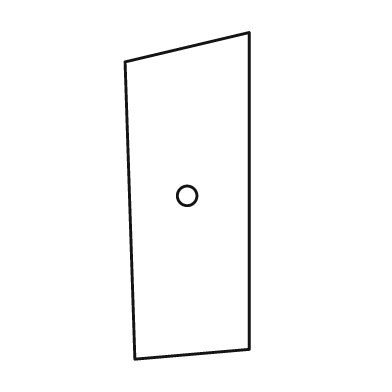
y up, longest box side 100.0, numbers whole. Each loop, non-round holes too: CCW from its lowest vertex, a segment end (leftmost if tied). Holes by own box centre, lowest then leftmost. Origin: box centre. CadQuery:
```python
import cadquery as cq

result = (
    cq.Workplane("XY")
    .moveTo(-16.0, -50.0)
    .lineTo(19.0, -47.0)
    .lineTo(19.0, 50.0)
    .lineTo(-19.0, 41.0)
    .close()
    .moveTo(0.0, 0.0)
    .circle(3.0)
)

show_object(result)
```